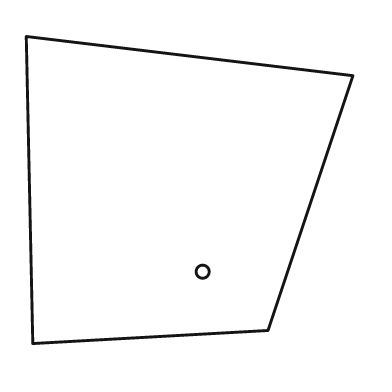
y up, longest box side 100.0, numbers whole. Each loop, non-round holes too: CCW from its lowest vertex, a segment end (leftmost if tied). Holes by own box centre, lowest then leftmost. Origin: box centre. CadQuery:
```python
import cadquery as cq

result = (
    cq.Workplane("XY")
    .moveTo(-48.0, -47.0)
    .lineTo(24.0, -43.0)
    .lineTo(50.0, 35.0)
    .lineTo(-50.0, 47.0)
    .close()
    .moveTo(4.0, -25.0)
    .circle(2.0)
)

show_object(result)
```